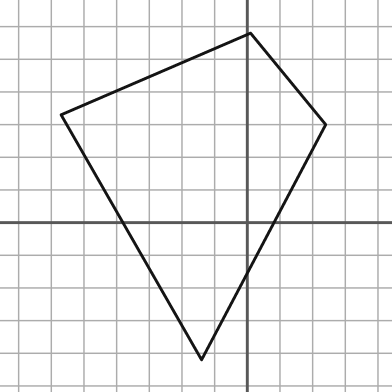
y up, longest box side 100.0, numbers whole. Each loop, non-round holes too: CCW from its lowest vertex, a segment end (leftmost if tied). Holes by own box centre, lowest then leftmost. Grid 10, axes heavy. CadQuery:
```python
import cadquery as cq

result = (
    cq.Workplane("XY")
    .moveTo(-14.0, -42.0)
    .lineTo(24.0, 30.0)
    .lineTo(1.0, 58.0)
    .lineTo(-57.0, 33.0)
    .close()
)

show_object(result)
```